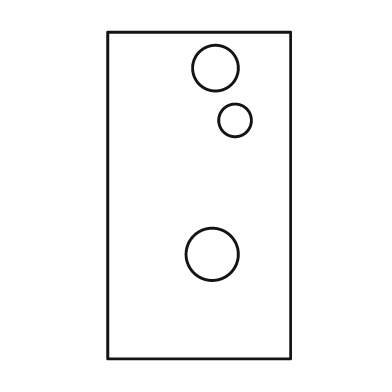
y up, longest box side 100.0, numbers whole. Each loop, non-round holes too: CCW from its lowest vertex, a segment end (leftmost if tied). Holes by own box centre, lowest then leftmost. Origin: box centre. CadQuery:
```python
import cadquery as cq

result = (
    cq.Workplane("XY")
    .moveTo(-28.0, -50.0)
    .lineTo(28.0, -50.0)
    .lineTo(28.0, 50.0)
    .lineTo(-28.0, 50.0)
    .close()
    .moveTo(4.0, -18.0)
    .circle(8.0)
    .moveTo(11.0, 23.0)
    .circle(5.0)
    .moveTo(5.0, 39.0)
    .circle(7.0)
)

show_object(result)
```